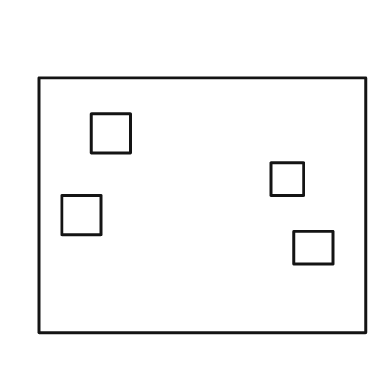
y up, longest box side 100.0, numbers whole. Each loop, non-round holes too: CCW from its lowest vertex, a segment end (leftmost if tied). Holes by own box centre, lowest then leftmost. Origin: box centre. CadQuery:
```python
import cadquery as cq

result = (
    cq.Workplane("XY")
    .moveTo(-50.0, -39.0)
    .lineTo(50.0, -39.0)
    .lineTo(50.0, 39.0)
    .lineTo(-50.0, 39.0)
    .close()
    .moveTo(28.0, -18.0)
    .lineTo(40.0, -18.0)
    .lineTo(40.0, -8.0)
    .lineTo(28.0, -8.0)
    .close()
    .moveTo(-43.0, -9.0)
    .lineTo(-31.0, -9.0)
    .lineTo(-31.0, 3.0)
    .lineTo(-43.0, 3.0)
    .close()
    .moveTo(21.0, 3.0)
    .lineTo(31.0, 3.0)
    .lineTo(31.0, 13.0)
    .lineTo(21.0, 13.0)
    .close()
    .moveTo(-34.0, 16.0)
    .lineTo(-22.0, 16.0)
    .lineTo(-22.0, 28.0)
    .lineTo(-34.0, 28.0)
    .close()
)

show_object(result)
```